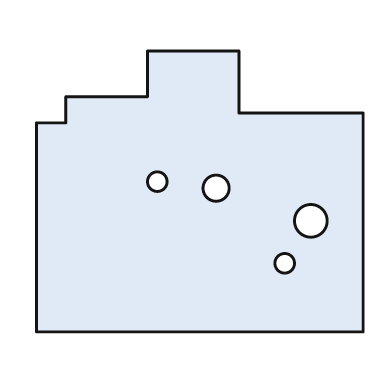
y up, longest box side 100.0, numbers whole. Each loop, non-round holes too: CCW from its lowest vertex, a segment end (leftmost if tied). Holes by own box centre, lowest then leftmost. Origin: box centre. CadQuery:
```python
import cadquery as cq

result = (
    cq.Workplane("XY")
    .moveTo(-50.0, -43.0)
    .lineTo(50.0, -43.0)
    .lineTo(50.0, 24.0)
    .lineTo(12.0, 24.0)
    .lineTo(12.0, 43.0)
    .lineTo(-16.0, 43.0)
    .lineTo(-16.0, 29.0)
    .lineTo(-41.0, 29.0)
    .lineTo(-41.0, 21.0)
    .lineTo(-50.0, 21.0)
    .close()
    .moveTo(26.0, -22.0)
    .circle(3.0)
    .moveTo(34.0, -9.0)
    .circle(5.0)
    .moveTo(5.0, 1.0)
    .circle(4.0)
    .moveTo(-13.0, 3.0)
    .circle(3.0)
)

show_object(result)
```